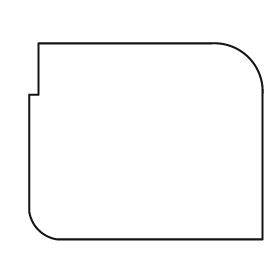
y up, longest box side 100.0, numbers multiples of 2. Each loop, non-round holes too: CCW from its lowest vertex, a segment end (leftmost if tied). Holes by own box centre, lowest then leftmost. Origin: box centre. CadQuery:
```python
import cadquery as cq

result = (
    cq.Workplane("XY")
    .moveTo(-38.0, -42.0)
    .lineTo(50.0, -42.0)
    .lineTo(50.0, 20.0)
    .threePointArc((44.0, 36.0), (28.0, 42.0))
    .lineTo(-46.0, 42.0)
    .lineTo(-46.0, 20.0)
    .lineTo(-50.0, 20.0)
    .lineTo(-50.0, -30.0)
    .threePointArc((-46.0, -38.0), (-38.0, -42.0))
    .close()
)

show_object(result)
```